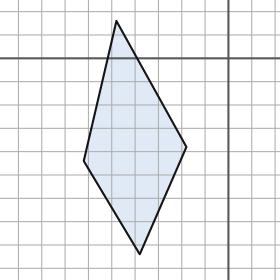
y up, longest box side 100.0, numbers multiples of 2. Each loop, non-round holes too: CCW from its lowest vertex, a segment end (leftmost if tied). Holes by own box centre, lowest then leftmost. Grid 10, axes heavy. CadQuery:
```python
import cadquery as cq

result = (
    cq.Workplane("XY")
    .moveTo(-38.0, -84.0)
    .lineTo(-18.0, -38.0)
    .lineTo(-48.0, 16.0)
    .lineTo(-62.0, -44.0)
    .close()
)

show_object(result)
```